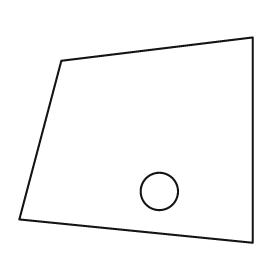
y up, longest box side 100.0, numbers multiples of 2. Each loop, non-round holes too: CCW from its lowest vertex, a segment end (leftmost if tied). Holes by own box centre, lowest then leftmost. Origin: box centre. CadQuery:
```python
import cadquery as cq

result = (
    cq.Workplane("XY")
    .moveTo(50.0, -44.0)
    .lineTo(50.0, 44.0)
    .lineTo(-32.0, 34.0)
    .lineTo(-50.0, -34.0)
    .close()
    .moveTo(10.0, -22.0)
    .circle(8.0)
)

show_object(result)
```